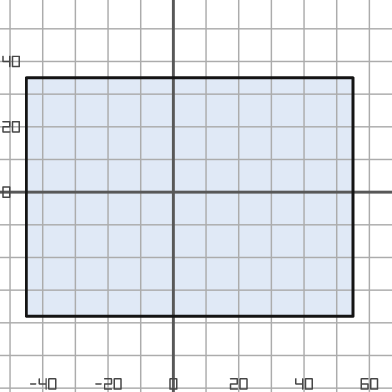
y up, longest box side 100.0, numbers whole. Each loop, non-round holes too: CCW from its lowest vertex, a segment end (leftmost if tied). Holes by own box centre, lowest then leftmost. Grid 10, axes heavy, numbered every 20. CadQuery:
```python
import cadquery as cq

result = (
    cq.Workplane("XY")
    .moveTo(-45.0, -38.0)
    .lineTo(55.0, -38.0)
    .lineTo(55.0, 35.0)
    .lineTo(-45.0, 35.0)
    .close()
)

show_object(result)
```